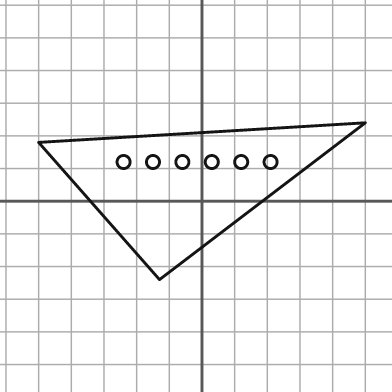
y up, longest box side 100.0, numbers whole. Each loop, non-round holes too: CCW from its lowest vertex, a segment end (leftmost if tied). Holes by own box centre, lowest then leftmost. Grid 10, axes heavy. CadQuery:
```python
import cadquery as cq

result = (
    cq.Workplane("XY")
    .moveTo(-13.0, -24.0)
    .lineTo(50.0, 24.0)
    .lineTo(-50.0, 18.0)
    .close()
    .moveTo(-24.0, 12.0)
    .circle(2.0)
    .moveTo(-15.0, 12.0)
    .circle(2.0)
    .moveTo(-6.0, 12.0)
    .circle(2.0)
    .moveTo(3.0, 12.0)
    .circle(2.0)
    .moveTo(12.0, 12.0)
    .circle(2.0)
    .moveTo(21.0, 12.0)
    .circle(2.0)
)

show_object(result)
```